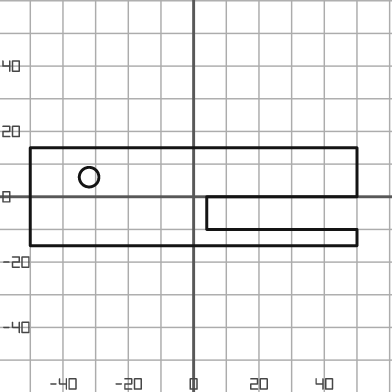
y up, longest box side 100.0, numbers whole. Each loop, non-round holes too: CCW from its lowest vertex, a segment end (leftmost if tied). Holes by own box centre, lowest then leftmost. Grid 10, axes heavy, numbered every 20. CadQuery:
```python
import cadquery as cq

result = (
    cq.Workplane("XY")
    .moveTo(-50.0, -15.0)
    .lineTo(50.0, -15.0)
    .lineTo(50.0, -10.0)
    .lineTo(4.0, -10.0)
    .lineTo(4.0, 0.0)
    .lineTo(50.0, 0.0)
    .lineTo(50.0, 15.0)
    .lineTo(-50.0, 15.0)
    .close()
    .moveTo(-32.0, 6.0)
    .circle(3.0)
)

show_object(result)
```